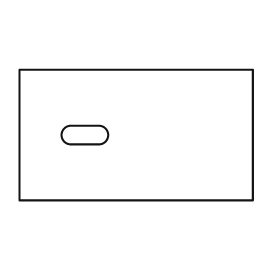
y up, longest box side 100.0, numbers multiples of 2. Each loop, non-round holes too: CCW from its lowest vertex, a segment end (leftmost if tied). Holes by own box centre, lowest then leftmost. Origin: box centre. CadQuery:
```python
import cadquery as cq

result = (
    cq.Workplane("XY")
    .moveTo(-50.0, -28.0)
    .lineTo(50.0, -28.0)
    .lineTo(50.0, 28.0)
    .lineTo(-50.0, 28.0)
    .close()
    .moveTo(-28.0, -4.0)
    .lineTo(-16.0, -4.0)
    .threePointArc((-12.0, 0.0), (-16.0, 4.0))
    .lineTo(-28.0, 4.0)
    .threePointArc((-32.0, 0.0), (-28.0, -4.0))
    .close()
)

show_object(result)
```